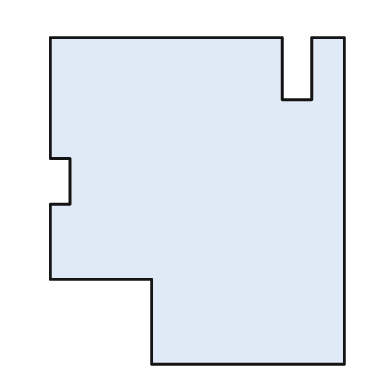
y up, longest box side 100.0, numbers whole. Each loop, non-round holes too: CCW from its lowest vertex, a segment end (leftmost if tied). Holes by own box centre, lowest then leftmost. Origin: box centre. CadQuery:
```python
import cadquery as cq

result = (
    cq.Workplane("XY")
    .moveTo(-14.0, -50.0)
    .lineTo(45.0, -50.0)
    .lineTo(45.0, 50.0)
    .lineTo(35.0, 50.0)
    .lineTo(35.0, 31.0)
    .lineTo(26.0, 31.0)
    .lineTo(26.0, 50.0)
    .lineTo(-45.0, 50.0)
    .lineTo(-45.0, 13.0)
    .lineTo(-39.0, 13.0)
    .lineTo(-39.0, -1.0)
    .lineTo(-45.0, -1.0)
    .lineTo(-45.0, -24.0)
    .lineTo(-14.0, -24.0)
    .close()
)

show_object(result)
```